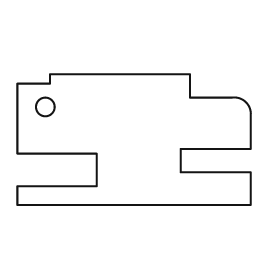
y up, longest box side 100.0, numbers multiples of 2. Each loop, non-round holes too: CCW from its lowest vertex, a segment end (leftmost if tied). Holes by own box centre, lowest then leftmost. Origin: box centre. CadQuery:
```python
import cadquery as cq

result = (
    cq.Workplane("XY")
    .moveTo(-50.0, -28.0)
    .lineTo(50.0, -28.0)
    .lineTo(50.0, -14.0)
    .lineTo(20.0, -14.0)
    .lineTo(20.0, -4.0)
    .lineTo(50.0, -4.0)
    .lineTo(50.0, 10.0)
    .threePointArc((48.0, 16.0), (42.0, 18.0))
    .lineTo(24.0, 18.0)
    .lineTo(24.0, 28.0)
    .lineTo(-36.0, 28.0)
    .lineTo(-36.0, 24.0)
    .lineTo(-50.0, 24.0)
    .lineTo(-50.0, -6.0)
    .lineTo(-16.0, -6.0)
    .lineTo(-16.0, -20.0)
    .lineTo(-50.0, -20.0)
    .close()
    .moveTo(-38.0, 14.0)
    .circle(4.0)
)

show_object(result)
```